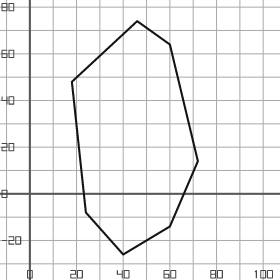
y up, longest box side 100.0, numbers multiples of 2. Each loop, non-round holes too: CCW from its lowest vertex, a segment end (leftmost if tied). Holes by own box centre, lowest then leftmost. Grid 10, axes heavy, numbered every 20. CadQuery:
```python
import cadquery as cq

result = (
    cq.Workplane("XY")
    .moveTo(40.0, -26.0)
    .lineTo(60.0, -14.0)
    .lineTo(72.0, 14.0)
    .lineTo(60.0, 64.0)
    .lineTo(46.0, 74.0)
    .lineTo(18.0, 48.0)
    .lineTo(24.0, -8.0)
    .close()
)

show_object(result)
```